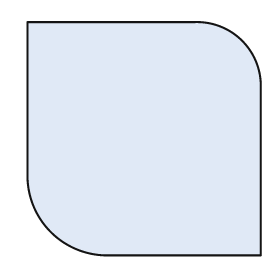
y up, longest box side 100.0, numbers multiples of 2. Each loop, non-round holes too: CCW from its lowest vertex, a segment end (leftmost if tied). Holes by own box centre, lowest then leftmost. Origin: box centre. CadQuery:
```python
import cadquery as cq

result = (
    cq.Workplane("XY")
    .moveTo(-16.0, -50.0)
    .lineTo(50.0, -50.0)
    .lineTo(50.0, 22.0)
    .threePointArc((42.0, 42.0), (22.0, 50.0))
    .lineTo(-50.0, 50.0)
    .lineTo(-50.0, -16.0)
    .threePointArc((-40.0, -40.0), (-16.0, -50.0))
    .close()
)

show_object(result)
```